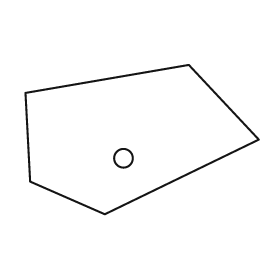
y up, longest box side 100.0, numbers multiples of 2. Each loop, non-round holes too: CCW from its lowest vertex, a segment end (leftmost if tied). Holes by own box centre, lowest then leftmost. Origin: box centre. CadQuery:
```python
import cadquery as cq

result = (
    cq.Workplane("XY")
    .moveTo(-16.0, -32.0)
    .lineTo(50.0, 0.0)
    .lineTo(20.0, 32.0)
    .lineTo(-50.0, 20.0)
    .lineTo(-48.0, -18.0)
    .close()
    .moveTo(-8.0, -8.0)
    .circle(4.0)
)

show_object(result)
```